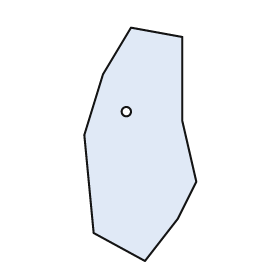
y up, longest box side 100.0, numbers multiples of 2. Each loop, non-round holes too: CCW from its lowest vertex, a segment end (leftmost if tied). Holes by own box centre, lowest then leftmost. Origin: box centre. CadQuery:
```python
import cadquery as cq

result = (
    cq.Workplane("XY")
    .moveTo(2.0, -50.0)
    .lineTo(16.0, -32.0)
    .lineTo(24.0, -16.0)
    .lineTo(18.0, 10.0)
    .lineTo(18.0, 46.0)
    .lineTo(-4.0, 50.0)
    .lineTo(-16.0, 30.0)
    .lineTo(-24.0, 4.0)
    .lineTo(-20.0, -38.0)
    .close()
    .moveTo(-6.0, 14.0)
    .circle(2.0)
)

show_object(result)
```